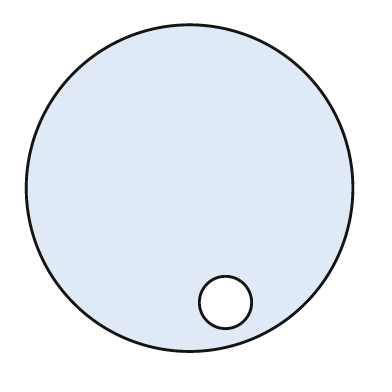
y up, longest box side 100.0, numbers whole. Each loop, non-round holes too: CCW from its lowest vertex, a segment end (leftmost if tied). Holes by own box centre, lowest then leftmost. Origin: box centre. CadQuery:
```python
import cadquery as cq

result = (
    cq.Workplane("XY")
    .moveTo(0.0, 0.0)
    .circle(50.0)
    .moveTo(11.0, -35.0)
    .circle(8.0)
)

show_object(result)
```